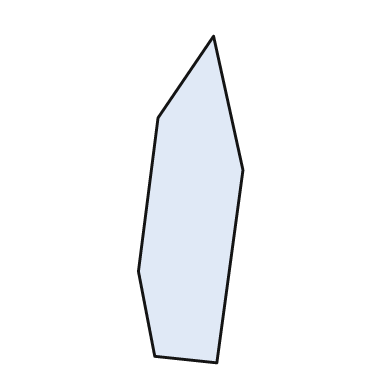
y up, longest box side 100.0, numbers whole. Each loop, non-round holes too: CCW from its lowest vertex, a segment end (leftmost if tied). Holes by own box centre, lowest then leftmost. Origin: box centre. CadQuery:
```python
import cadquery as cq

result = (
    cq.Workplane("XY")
    .moveTo(8.0, -50.0)
    .lineTo(16.0, 9.0)
    .lineTo(7.0, 50.0)
    .lineTo(-10.0, 25.0)
    .lineTo(-16.0, -22.0)
    .lineTo(-11.0, -48.0)
    .close()
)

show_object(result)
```